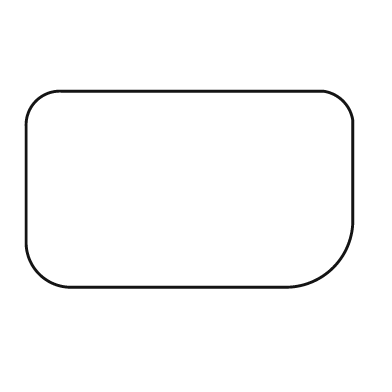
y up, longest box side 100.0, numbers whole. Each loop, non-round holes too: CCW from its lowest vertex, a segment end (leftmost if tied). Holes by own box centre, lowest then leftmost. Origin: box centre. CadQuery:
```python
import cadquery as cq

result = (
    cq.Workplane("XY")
    .moveTo(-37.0, -30.0)
    .lineTo(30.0, -30.0)
    .threePointArc((44.0, -24.0), (50.0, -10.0))
    .lineTo(50.0, 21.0)
    .threePointArc((47.0, 27.0), (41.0, 30.0))
    .lineTo(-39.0, 30.0)
    .threePointArc((-47.0, 27.0), (-50.0, 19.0))
    .lineTo(-50.0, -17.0)
    .threePointArc((-46.0, -26.0), (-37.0, -30.0))
    .close()
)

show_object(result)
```